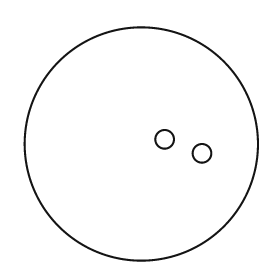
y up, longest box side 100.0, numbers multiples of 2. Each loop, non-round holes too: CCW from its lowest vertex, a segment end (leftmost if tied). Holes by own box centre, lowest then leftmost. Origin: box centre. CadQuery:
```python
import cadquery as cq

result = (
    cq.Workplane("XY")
    .moveTo(0.0, 0.0)
    .circle(50.0)
    .moveTo(26.0, -4.0)
    .circle(4.0)
    .moveTo(10.0, 2.0)
    .circle(4.0)
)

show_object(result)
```